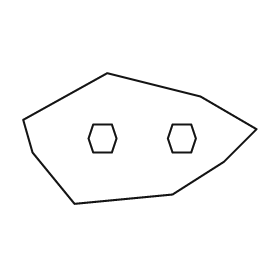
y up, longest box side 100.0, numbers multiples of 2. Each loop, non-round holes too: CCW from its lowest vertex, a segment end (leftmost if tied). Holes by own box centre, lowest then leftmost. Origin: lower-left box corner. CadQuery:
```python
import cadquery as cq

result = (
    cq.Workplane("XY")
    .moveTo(22.0, 0.0)
    .lineTo(64.0, 4.0)
    .lineTo(86.0, 18.0)
    .lineTo(100.0, 32.0)
    .lineTo(76.0, 46.0)
    .lineTo(36.0, 56.0)
    .lineTo(0.0, 36.0)
    .lineTo(4.0, 22.0)
    .close()
    .moveTo(30.0, 22.0)
    .lineTo(38.0, 22.0)
    .lineTo(40.0, 28.0)
    .lineTo(38.0, 34.0)
    .lineTo(30.0, 34.0)
    .lineTo(28.0, 28.0)
    .close()
    .moveTo(64.0, 22.0)
    .lineTo(72.0, 22.0)
    .lineTo(74.0, 28.0)
    .lineTo(72.0, 34.0)
    .lineTo(64.0, 34.0)
    .lineTo(62.0, 28.0)
    .close()
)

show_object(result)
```